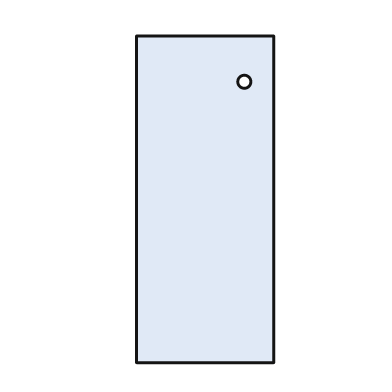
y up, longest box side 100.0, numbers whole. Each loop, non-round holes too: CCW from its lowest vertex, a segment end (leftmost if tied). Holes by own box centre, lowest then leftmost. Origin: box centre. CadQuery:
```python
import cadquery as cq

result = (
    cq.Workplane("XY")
    .moveTo(-21.0, -50.0)
    .lineTo(21.0, -50.0)
    .lineTo(21.0, 50.0)
    .lineTo(-21.0, 50.0)
    .close()
    .moveTo(12.0, 36.0)
    .circle(2.0)
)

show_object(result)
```